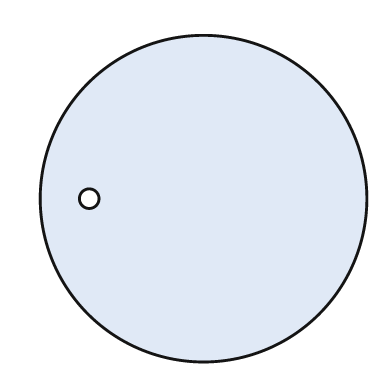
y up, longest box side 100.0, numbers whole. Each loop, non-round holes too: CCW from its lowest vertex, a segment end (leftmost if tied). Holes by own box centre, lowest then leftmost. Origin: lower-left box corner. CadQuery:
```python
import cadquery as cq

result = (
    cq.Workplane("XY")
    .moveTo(50.0, 50.0)
    .circle(50.0)
    .moveTo(15.0, 50.0)
    .circle(3.0)
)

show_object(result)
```